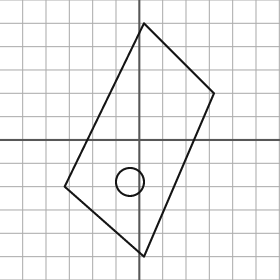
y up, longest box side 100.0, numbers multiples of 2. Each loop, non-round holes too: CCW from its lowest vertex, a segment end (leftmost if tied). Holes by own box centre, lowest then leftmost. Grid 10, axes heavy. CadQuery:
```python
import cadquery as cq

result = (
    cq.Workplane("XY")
    .moveTo(2.0, -50.0)
    .lineTo(32.0, 20.0)
    .lineTo(2.0, 50.0)
    .lineTo(-32.0, -20.0)
    .close()
    .moveTo(-4.0, -18.0)
    .circle(6.0)
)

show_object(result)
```